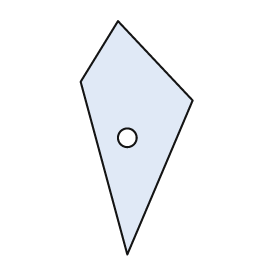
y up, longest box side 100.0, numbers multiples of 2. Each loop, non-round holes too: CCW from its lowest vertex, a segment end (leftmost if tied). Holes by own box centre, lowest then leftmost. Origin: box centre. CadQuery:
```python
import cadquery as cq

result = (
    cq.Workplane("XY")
    .moveTo(-4.0, -50.0)
    .lineTo(24.0, 16.0)
    .lineTo(-8.0, 50.0)
    .lineTo(-24.0, 24.0)
    .close()
    .moveTo(-4.0, 0.0)
    .circle(4.0)
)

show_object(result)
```